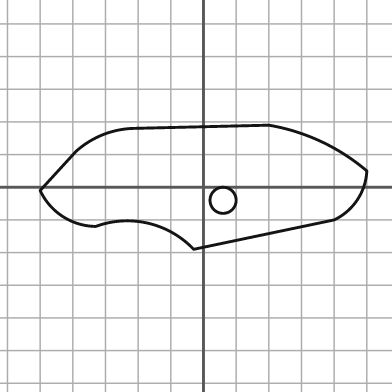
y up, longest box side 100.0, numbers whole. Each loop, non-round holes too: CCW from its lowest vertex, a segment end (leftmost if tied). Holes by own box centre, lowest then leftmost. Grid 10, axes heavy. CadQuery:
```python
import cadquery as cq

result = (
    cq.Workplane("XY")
    .moveTo(-3.0, -19.0)
    .lineTo(40.0, -10.0)
    .threePointArc((47.0, -4.0), (50.0, 5.0))
    .threePointArc((36.0, 14.0), (20.0, 19.0))
    .lineTo(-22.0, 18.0)
    .threePointArc((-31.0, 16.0), (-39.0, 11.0))
    .lineTo(-50.0, -1.0)
    .threePointArc((-43.0, -9.0), (-33.0, -12.0))
    .threePointArc((-17.0, -11.0), (-3.0, -19.0))
    .close()
    .moveTo(6.0, -4.0)
    .circle(4.0)
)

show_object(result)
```